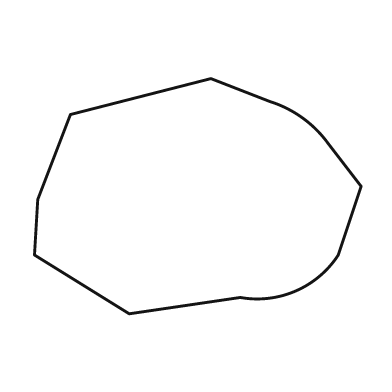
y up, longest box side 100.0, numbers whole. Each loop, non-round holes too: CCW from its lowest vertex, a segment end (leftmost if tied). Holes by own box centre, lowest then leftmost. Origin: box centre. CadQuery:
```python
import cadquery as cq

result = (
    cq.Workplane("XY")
    .moveTo(-21.0, -36.0)
    .lineTo(13.0, -31.0)
    .threePointArc((30.0, -29.0), (43.0, -18.0))
    .lineTo(50.0, 3.0)
    .lineTo(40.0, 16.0)
    .threePointArc((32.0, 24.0), (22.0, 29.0))
    .lineTo(4.0, 36.0)
    .lineTo(-39.0, 25.0)
    .lineTo(-49.0, -1.0)
    .lineTo(-50.0, -18.0)
    .close()
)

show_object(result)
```